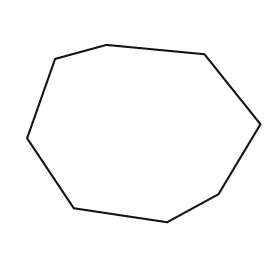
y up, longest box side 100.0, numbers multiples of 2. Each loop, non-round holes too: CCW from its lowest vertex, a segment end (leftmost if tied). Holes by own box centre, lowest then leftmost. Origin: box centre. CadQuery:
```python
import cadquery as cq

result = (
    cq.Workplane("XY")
    .moveTo(10.0, -38.0)
    .lineTo(32.0, -26.0)
    .lineTo(50.0, 4.0)
    .lineTo(26.0, 34.0)
    .lineTo(-16.0, 38.0)
    .lineTo(-38.0, 32.0)
    .lineTo(-50.0, -2.0)
    .lineTo(-30.0, -32.0)
    .close()
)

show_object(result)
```